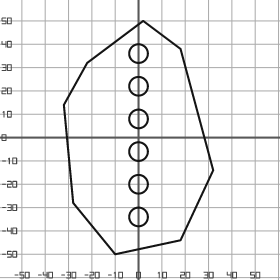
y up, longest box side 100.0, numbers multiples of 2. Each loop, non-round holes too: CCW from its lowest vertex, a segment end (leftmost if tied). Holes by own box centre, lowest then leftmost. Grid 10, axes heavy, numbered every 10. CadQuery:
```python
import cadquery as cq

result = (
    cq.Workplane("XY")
    .moveTo(-10.0, -50.0)
    .lineTo(18.0, -44.0)
    .lineTo(32.0, -14.0)
    .lineTo(18.0, 38.0)
    .lineTo(2.0, 50.0)
    .lineTo(-22.0, 32.0)
    .lineTo(-32.0, 14.0)
    .lineTo(-28.0, -28.0)
    .close()
    .moveTo(0.0, -34.0)
    .circle(4.0)
    .moveTo(0.0, -20.0)
    .circle(4.0)
    .moveTo(0.0, -6.0)
    .circle(4.0)
    .moveTo(0.0, 8.0)
    .circle(4.0)
    .moveTo(0.0, 22.0)
    .circle(4.0)
    .moveTo(0.0, 36.0)
    .circle(4.0)
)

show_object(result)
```